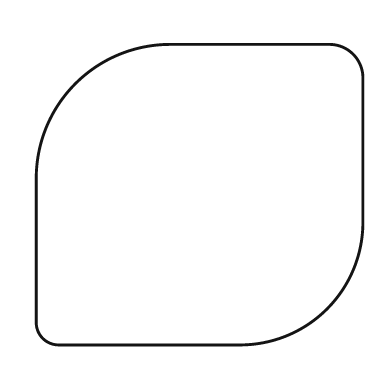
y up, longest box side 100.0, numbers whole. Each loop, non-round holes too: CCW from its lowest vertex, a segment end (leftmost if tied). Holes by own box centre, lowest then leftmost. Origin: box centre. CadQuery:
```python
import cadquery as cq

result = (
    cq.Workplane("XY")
    .moveTo(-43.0, -46.0)
    .lineTo(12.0, -46.0)
    .threePointArc((39.0, -35.0), (50.0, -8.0))
    .lineTo(50.0, 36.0)
    .threePointArc((47.0, 43.0), (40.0, 46.0))
    .lineTo(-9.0, 46.0)
    .threePointArc((-38.0, 34.0), (-50.0, 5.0))
    .lineTo(-50.0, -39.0)
    .threePointArc((-48.0, -44.0), (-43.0, -46.0))
    .close()
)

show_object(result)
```